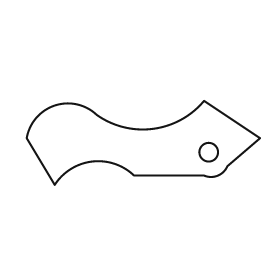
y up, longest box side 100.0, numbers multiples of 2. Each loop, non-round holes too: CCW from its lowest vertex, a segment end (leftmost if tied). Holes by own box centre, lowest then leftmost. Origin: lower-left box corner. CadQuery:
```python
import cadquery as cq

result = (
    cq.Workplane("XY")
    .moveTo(12.0, 0.0)
    .threePointArc((28.0, 10.0), (46.0, 4.0))
    .lineTo(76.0, 4.0)
    .threePointArc((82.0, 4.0), (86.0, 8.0))
    .lineTo(100.0, 20.0)
    .lineTo(76.0, 36.0)
    .threePointArc((54.0, 24.0), (30.0, 30.0))
    .threePointArc((12.0, 34.0), (0.0, 20.0))
    .close()
    .moveTo(78.0, 14.0)
    .circle(4.0)
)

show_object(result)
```